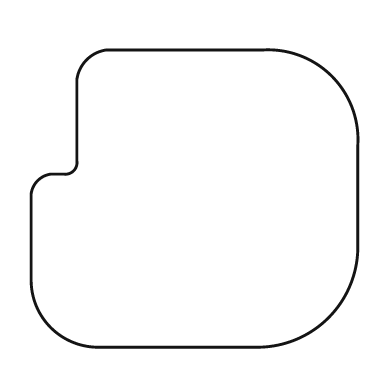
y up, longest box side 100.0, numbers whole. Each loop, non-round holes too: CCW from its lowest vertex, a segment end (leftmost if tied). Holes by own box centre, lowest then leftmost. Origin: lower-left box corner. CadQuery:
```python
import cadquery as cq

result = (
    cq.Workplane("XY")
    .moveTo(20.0, 0.0)
    .lineTo(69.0, 0.0)
    .threePointArc((91.0, 9.0), (100.0, 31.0))
    .lineTo(100.0, 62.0)
    .threePointArc((92.0, 83.0), (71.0, 91.0))
    .lineTo(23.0, 91.0)
    .threePointArc((17.0, 88.0), (14.0, 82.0))
    .lineTo(14.0, 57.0)
    .threePointArc((13.0, 54.0), (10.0, 53.0))
    .lineTo(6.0, 53.0)
    .threePointArc((2.0, 51.0), (0.0, 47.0))
    .lineTo(0.0, 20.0)
    .threePointArc((6.0, 6.0), (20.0, 0.0))
    .close()
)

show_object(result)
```